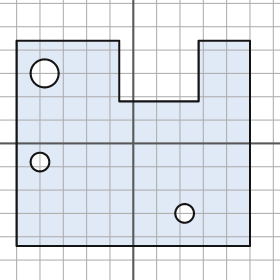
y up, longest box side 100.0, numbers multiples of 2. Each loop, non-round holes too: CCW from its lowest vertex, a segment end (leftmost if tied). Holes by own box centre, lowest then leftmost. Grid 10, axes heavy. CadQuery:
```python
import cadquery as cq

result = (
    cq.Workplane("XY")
    .moveTo(-50.0, -44.0)
    .lineTo(50.0, -44.0)
    .lineTo(50.0, 44.0)
    .lineTo(28.0, 44.0)
    .lineTo(28.0, 18.0)
    .lineTo(-6.0, 18.0)
    .lineTo(-6.0, 44.0)
    .lineTo(-50.0, 44.0)
    .close()
    .moveTo(22.0, -30.0)
    .circle(4.0)
    .moveTo(-40.0, -8.0)
    .circle(4.0)
    .moveTo(-38.0, 30.0)
    .circle(6.0)
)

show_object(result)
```